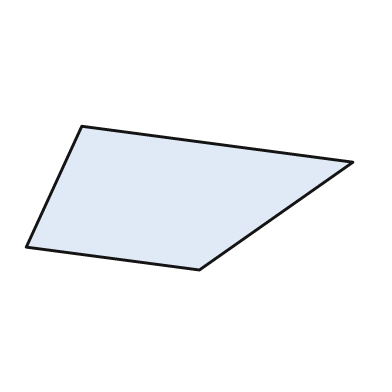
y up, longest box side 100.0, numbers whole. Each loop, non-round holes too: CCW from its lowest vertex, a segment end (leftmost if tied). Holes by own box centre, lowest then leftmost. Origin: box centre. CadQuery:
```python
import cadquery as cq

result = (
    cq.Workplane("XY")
    .moveTo(3.0, -22.0)
    .lineTo(50.0, 11.0)
    .lineTo(-33.0, 22.0)
    .lineTo(-50.0, -15.0)
    .close()
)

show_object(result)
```